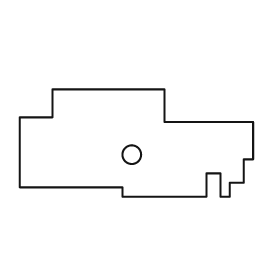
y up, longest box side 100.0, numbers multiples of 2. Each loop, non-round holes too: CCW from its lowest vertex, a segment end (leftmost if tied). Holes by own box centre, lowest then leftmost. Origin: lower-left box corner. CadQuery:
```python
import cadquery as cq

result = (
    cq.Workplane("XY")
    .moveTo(44.0, 0.0)
    .lineTo(80.0, 0.0)
    .lineTo(80.0, 10.0)
    .lineTo(86.0, 10.0)
    .lineTo(86.0, 0.0)
    .lineTo(90.0, 0.0)
    .lineTo(90.0, 6.0)
    .lineTo(96.0, 6.0)
    .lineTo(96.0, 16.0)
    .lineTo(100.0, 16.0)
    .lineTo(100.0, 32.0)
    .lineTo(62.0, 32.0)
    .lineTo(62.0, 46.0)
    .lineTo(14.0, 46.0)
    .lineTo(14.0, 34.0)
    .lineTo(0.0, 34.0)
    .lineTo(0.0, 4.0)
    .lineTo(44.0, 4.0)
    .close()
    .moveTo(48.0, 18.0)
    .circle(4.0)
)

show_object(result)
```